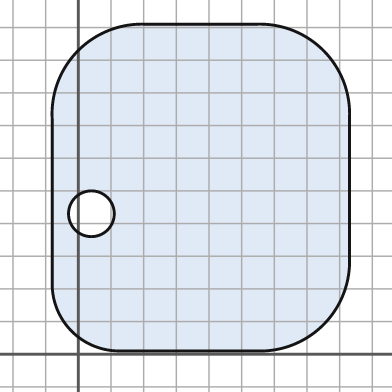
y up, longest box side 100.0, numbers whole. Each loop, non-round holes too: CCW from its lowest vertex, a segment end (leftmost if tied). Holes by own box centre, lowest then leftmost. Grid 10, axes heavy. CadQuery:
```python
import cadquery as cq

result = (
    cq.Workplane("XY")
    .moveTo(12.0, 1.0)
    .lineTo(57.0, 1.0)
    .threePointArc((75.0, 9.0), (83.0, 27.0))
    .lineTo(83.0, 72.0)
    .threePointArc((75.0, 93.0), (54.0, 101.0))
    .lineTo(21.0, 101.0)
    .threePointArc((0.0, 93.0), (-8.0, 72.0))
    .lineTo(-8.0, 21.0)
    .threePointArc((-2.0, 7.0), (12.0, 1.0))
    .close()
    .moveTo(4.0, 43.0)
    .circle(7.0)
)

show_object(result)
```